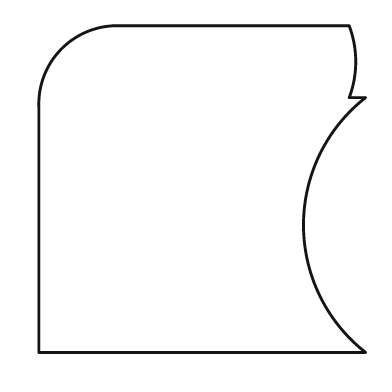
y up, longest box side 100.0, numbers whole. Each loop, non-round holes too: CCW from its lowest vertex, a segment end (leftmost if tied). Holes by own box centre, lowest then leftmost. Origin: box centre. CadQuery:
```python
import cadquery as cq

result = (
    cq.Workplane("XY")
    .moveTo(-50.0, -50.0)
    .lineTo(50.0, -50.0)
    .threePointArc((31.0, -11.0), (50.0, 28.0))
    .lineTo(45.0, 28.0)
    .threePointArc((47.0, 39.0), (45.0, 50.0))
    .lineTo(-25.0, 50.0)
    .threePointArc((-43.0, 43.0), (-50.0, 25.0))
    .close()
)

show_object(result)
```